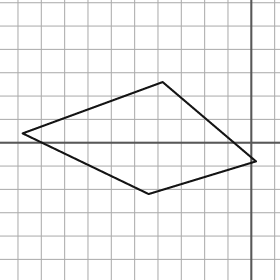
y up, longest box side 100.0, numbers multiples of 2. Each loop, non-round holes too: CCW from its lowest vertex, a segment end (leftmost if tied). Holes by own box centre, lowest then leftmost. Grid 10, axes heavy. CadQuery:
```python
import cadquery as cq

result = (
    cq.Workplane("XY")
    .moveTo(-44.0, -22.0)
    .lineTo(2.0, -8.0)
    .lineTo(-38.0, 26.0)
    .lineTo(-98.0, 4.0)
    .close()
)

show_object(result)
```